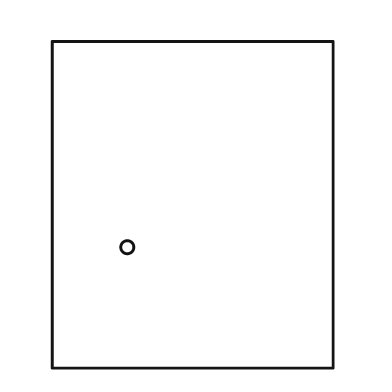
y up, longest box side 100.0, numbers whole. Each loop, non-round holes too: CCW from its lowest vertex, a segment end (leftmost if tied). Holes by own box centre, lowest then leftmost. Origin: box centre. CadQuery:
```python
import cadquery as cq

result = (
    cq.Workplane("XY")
    .moveTo(-43.0, -50.0)
    .lineTo(43.0, -50.0)
    .lineTo(43.0, 50.0)
    .lineTo(-43.0, 50.0)
    .close()
    .moveTo(-20.0, -13.0)
    .circle(2.0)
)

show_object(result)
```